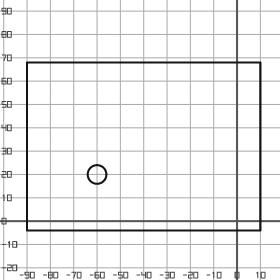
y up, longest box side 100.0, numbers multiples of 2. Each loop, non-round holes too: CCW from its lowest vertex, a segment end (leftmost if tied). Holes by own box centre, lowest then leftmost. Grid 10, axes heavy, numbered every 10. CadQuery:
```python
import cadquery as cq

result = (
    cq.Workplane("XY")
    .moveTo(-90.0, -4.0)
    .lineTo(10.0, -4.0)
    .lineTo(10.0, 68.0)
    .lineTo(-90.0, 68.0)
    .close()
    .moveTo(-60.0, 20.0)
    .circle(4.0)
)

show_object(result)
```